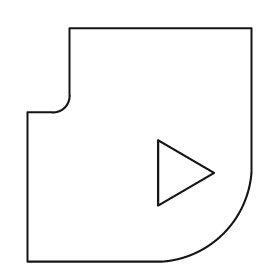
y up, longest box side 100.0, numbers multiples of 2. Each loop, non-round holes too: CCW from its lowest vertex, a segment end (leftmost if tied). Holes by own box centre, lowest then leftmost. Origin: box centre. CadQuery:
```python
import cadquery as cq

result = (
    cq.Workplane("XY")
    .moveTo(-48.0, -50.0)
    .lineTo(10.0, -50.0)
    .threePointArc((36.0, -38.0), (48.0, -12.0))
    .lineTo(48.0, 50.0)
    .lineTo(-30.0, 50.0)
    .lineTo(-30.0, 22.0)
    .threePointArc((-32.0, 16.0), (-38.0, 14.0))
    .lineTo(-48.0, 14.0)
    .close()
    .moveTo(8.0, -26.0)
    .lineTo(32.0, -12.0)
    .lineTo(8.0, 2.0)
    .close()
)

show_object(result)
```